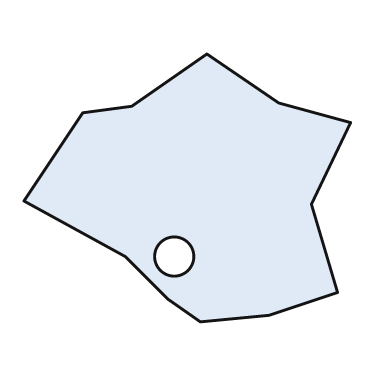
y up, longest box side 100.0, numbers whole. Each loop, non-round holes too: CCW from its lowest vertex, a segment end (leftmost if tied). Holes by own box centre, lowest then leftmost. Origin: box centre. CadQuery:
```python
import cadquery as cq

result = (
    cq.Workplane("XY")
    .moveTo(4.0, -41.0)
    .lineTo(25.0, -39.0)
    .lineTo(46.0, -32.0)
    .lineTo(38.0, -5.0)
    .lineTo(50.0, 20.0)
    .lineTo(28.0, 26.0)
    .lineTo(6.0, 41.0)
    .lineTo(-17.0, 25.0)
    .lineTo(-32.0, 23.0)
    .lineTo(-50.0, -4.0)
    .lineTo(-19.0, -21.0)
    .lineTo(-6.0, -34.0)
    .close()
    .moveTo(-4.0, -21.0)
    .circle(6.0)
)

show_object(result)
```